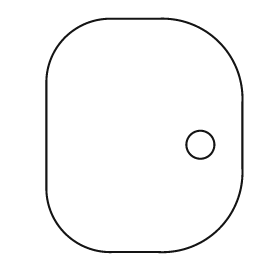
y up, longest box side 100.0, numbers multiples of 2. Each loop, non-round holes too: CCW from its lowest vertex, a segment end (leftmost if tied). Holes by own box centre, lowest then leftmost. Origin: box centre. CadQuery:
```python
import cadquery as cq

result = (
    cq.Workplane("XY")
    .moveTo(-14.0, -50.0)
    .lineTo(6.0, -50.0)
    .threePointArc((32.0, -40.0), (42.0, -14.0))
    .lineTo(42.0, 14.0)
    .threePointArc((32.0, 40.0), (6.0, 50.0))
    .lineTo(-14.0, 50.0)
    .threePointArc((-34.0, 42.0), (-42.0, 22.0))
    .lineTo(-42.0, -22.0)
    .threePointArc((-34.0, -42.0), (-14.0, -50.0))
    .close()
    .moveTo(24.0, -4.0)
    .circle(6.0)
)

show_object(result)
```